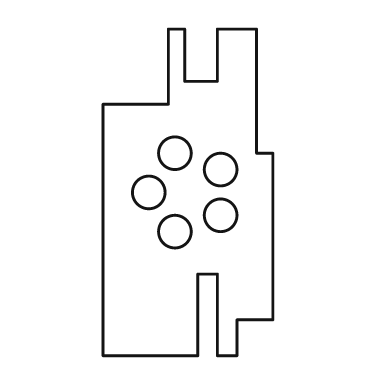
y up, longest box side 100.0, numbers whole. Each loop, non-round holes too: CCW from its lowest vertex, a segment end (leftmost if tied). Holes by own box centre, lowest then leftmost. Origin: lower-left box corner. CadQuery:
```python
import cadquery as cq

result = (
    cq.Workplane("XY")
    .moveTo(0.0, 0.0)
    .lineTo(29.0, 0.0)
    .lineTo(29.0, 25.0)
    .lineTo(35.0, 25.0)
    .lineTo(35.0, 0.0)
    .lineTo(41.0, 0.0)
    .lineTo(41.0, 11.0)
    .lineTo(52.0, 11.0)
    .lineTo(52.0, 62.0)
    .lineTo(47.0, 62.0)
    .lineTo(47.0, 100.0)
    .lineTo(35.0, 100.0)
    .lineTo(35.0, 84.0)
    .lineTo(25.0, 84.0)
    .lineTo(25.0, 100.0)
    .lineTo(20.0, 100.0)
    .lineTo(20.0, 77.0)
    .lineTo(0.0, 77.0)
    .close()
    .moveTo(22.0, 38.0)
    .circle(5.0)
    .moveTo(36.0, 43.0)
    .circle(5.0)
    .moveTo(14.0, 50.0)
    .circle(5.0)
    .moveTo(36.0, 57.0)
    .circle(5.0)
    .moveTo(22.0, 62.0)
    .circle(5.0)
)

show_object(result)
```